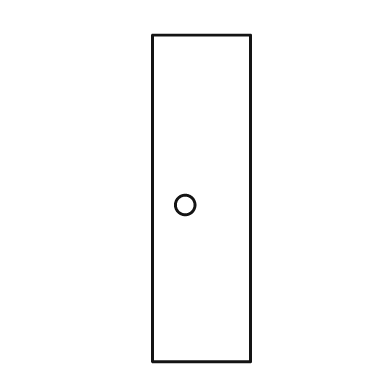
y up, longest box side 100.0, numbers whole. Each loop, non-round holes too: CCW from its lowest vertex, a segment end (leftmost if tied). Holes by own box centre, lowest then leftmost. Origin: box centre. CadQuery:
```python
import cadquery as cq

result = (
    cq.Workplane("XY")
    .moveTo(-15.0, -50.0)
    .lineTo(15.0, -50.0)
    .lineTo(15.0, 50.0)
    .lineTo(-15.0, 50.0)
    .close()
    .moveTo(-5.0, -2.0)
    .circle(3.0)
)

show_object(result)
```